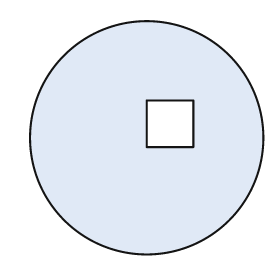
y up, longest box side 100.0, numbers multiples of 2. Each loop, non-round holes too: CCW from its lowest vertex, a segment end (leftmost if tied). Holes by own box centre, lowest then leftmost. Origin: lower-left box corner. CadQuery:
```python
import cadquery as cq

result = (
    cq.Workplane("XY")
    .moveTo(50.0, 50.0)
    .circle(50.0)
    .moveTo(50.0, 46.0)
    .lineTo(70.0, 46.0)
    .lineTo(70.0, 66.0)
    .lineTo(50.0, 66.0)
    .close()
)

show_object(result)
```